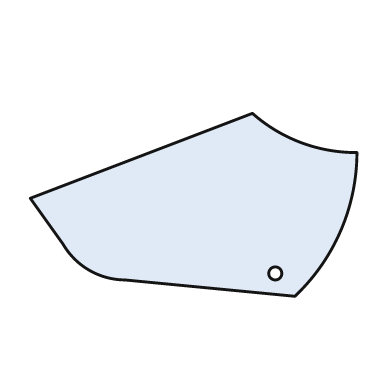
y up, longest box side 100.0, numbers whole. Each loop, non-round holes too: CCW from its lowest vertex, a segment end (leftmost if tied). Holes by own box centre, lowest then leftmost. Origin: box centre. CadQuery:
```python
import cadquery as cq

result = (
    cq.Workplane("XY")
    .moveTo(31.0, -28.0)
    .threePointArc((45.0, -8.0), (50.0, 16.0))
    .threePointArc((33.0, 19.0), (18.0, 28.0))
    .lineTo(-50.0, 2.0)
    .lineTo(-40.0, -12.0)
    .threePointArc((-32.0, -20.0), (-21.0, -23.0))
    .close()
    .moveTo(25.0, -21.0)
    .circle(2.0)
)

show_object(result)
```